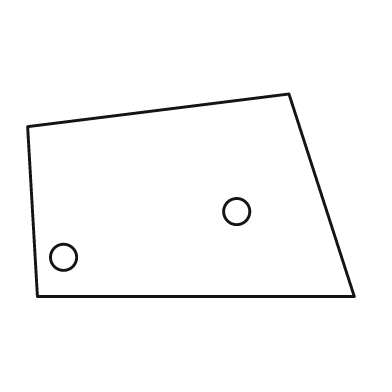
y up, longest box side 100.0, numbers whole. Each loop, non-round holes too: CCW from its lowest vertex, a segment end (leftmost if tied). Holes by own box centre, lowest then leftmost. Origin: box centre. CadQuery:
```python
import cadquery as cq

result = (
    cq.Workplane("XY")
    .moveTo(-47.0, -31.0)
    .lineTo(50.0, -31.0)
    .lineTo(30.0, 31.0)
    .lineTo(-50.0, 21.0)
    .close()
    .moveTo(-39.0, -19.0)
    .circle(4.0)
    .moveTo(14.0, -5.0)
    .circle(4.0)
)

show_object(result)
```